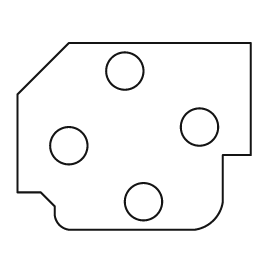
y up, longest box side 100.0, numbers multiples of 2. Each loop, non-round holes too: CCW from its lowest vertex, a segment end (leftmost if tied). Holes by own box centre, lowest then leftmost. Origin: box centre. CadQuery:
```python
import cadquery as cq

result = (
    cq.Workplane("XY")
    .moveTo(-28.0, -40.0)
    .lineTo(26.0, -40.0)
    .threePointArc((34.0, -36.0), (38.0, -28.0))
    .lineTo(38.0, -8.0)
    .lineTo(50.0, -8.0)
    .lineTo(50.0, 40.0)
    .lineTo(-28.0, 40.0)
    .lineTo(-50.0, 18.0)
    .lineTo(-50.0, -24.0)
    .lineTo(-40.0, -24.0)
    .lineTo(-34.0, -30.0)
    .lineTo(-34.0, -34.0)
    .threePointArc((-32.0, -38.0), (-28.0, -40.0))
    .close()
    .moveTo(4.0, -28.0)
    .circle(8.0)
    .moveTo(-28.0, -4.0)
    .circle(8.0)
    .moveTo(28.0, 4.0)
    .circle(8.0)
    .moveTo(-4.0, 28.0)
    .circle(8.0)
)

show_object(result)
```